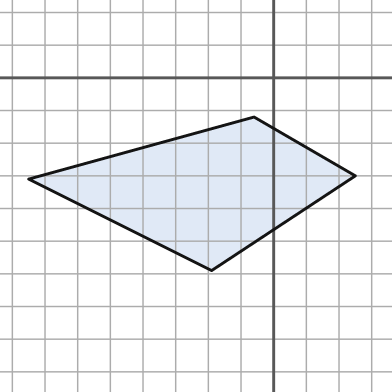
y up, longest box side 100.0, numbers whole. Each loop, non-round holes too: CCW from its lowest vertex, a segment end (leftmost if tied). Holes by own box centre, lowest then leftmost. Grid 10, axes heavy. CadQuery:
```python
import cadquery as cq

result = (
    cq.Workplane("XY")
    .moveTo(-19.0, -59.0)
    .lineTo(25.0, -30.0)
    .lineTo(-6.0, -12.0)
    .lineTo(-75.0, -31.0)
    .close()
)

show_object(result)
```